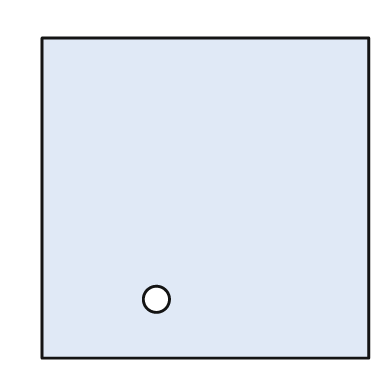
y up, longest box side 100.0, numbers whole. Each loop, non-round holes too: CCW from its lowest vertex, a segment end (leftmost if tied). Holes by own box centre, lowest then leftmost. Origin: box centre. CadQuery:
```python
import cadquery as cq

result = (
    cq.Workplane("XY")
    .moveTo(-50.0, -49.0)
    .lineTo(50.0, -49.0)
    .lineTo(50.0, 49.0)
    .lineTo(-50.0, 49.0)
    .close()
    .moveTo(-15.0, -31.0)
    .circle(4.0)
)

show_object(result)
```